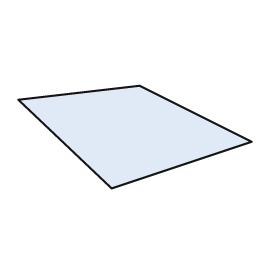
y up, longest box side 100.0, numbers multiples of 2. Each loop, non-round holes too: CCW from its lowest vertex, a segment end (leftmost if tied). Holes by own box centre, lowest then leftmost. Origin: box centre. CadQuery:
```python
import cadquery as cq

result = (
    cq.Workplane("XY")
    .moveTo(-10.0, -22.0)
    .lineTo(50.0, -2.0)
    .lineTo(2.0, 22.0)
    .lineTo(-50.0, 16.0)
    .close()
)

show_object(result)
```